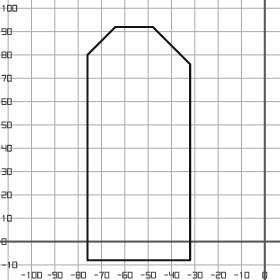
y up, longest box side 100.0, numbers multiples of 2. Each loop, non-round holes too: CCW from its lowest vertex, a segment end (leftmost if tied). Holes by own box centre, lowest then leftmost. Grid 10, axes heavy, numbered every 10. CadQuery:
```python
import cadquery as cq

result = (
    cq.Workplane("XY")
    .moveTo(-76.0, -8.0)
    .lineTo(-32.0, -8.0)
    .lineTo(-32.0, 76.0)
    .lineTo(-48.0, 92.0)
    .lineTo(-64.0, 92.0)
    .lineTo(-76.0, 80.0)
    .close()
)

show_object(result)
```